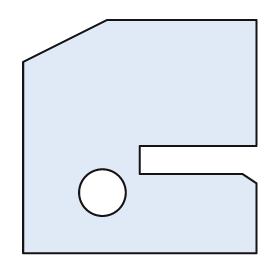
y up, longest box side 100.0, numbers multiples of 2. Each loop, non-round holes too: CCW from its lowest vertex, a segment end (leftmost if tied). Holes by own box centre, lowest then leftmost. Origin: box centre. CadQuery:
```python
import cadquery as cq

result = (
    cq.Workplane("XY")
    .moveTo(-50.0, -50.0)
    .lineTo(50.0, -50.0)
    .lineTo(50.0, -20.0)
    .lineTo(44.0, -16.0)
    .lineTo(0.0, -16.0)
    .lineTo(0.0, -4.0)
    .lineTo(50.0, -4.0)
    .lineTo(50.0, 50.0)
    .lineTo(-14.0, 50.0)
    .lineTo(-50.0, 32.0)
    .close()
    .moveTo(-16.0, -24.0)
    .circle(10.0)
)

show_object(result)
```